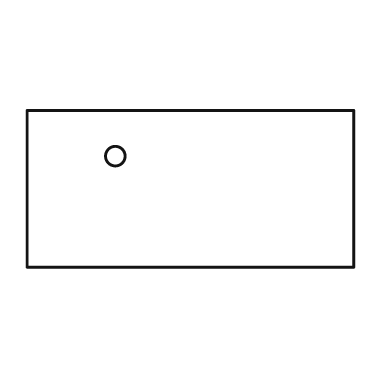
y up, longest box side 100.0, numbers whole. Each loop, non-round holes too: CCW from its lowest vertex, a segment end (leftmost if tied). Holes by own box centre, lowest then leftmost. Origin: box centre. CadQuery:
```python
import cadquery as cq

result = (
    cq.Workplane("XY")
    .moveTo(-50.0, -24.0)
    .lineTo(50.0, -24.0)
    .lineTo(50.0, 24.0)
    .lineTo(-50.0, 24.0)
    .close()
    .moveTo(-23.0, 10.0)
    .circle(3.0)
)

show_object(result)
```